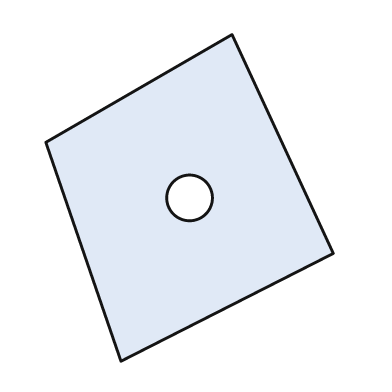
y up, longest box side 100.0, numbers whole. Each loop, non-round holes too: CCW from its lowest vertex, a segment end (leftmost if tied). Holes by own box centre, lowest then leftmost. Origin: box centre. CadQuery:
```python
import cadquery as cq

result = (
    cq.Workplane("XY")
    .moveTo(-21.0, -50.0)
    .lineTo(44.0, -17.0)
    .lineTo(13.0, 50.0)
    .lineTo(-44.0, 17.0)
    .close()
    .moveTo(0.0, 0.0)
    .circle(7.0)
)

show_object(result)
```